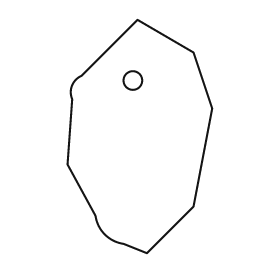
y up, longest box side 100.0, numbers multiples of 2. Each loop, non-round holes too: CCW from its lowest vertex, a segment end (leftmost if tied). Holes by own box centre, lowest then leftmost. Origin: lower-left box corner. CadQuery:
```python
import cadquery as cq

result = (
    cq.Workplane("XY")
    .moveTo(34.0, 0.0)
    .lineTo(54.0, 20.0)
    .lineTo(62.0, 62.0)
    .lineTo(54.0, 86.0)
    .lineTo(30.0, 100.0)
    .lineTo(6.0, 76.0)
    .threePointArc((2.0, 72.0), (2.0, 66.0))
    .lineTo(0.0, 38.0)
    .lineTo(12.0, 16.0)
    .threePointArc((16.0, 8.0), (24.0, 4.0))
    .close()
    .moveTo(28.0, 74.0)
    .circle(4.0)
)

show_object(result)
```